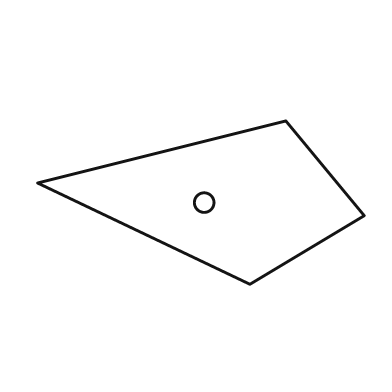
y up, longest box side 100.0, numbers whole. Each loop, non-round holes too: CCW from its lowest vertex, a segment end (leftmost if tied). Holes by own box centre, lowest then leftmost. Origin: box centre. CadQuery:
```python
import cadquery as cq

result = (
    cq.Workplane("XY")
    .moveTo(15.0, -25.0)
    .lineTo(50.0, -4.0)
    .lineTo(26.0, 25.0)
    .lineTo(-50.0, 6.0)
    .close()
    .moveTo(1.0, 0.0)
    .circle(3.0)
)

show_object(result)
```